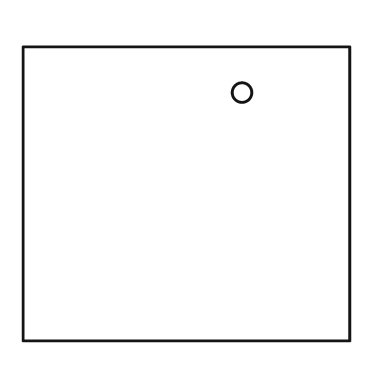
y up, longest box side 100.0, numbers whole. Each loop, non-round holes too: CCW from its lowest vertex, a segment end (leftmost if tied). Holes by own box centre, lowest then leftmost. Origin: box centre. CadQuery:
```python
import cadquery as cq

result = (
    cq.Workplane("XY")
    .moveTo(-50.0, -45.0)
    .lineTo(50.0, -45.0)
    .lineTo(50.0, 45.0)
    .lineTo(-50.0, 45.0)
    .close()
    .moveTo(17.0, 31.0)
    .circle(3.0)
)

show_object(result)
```